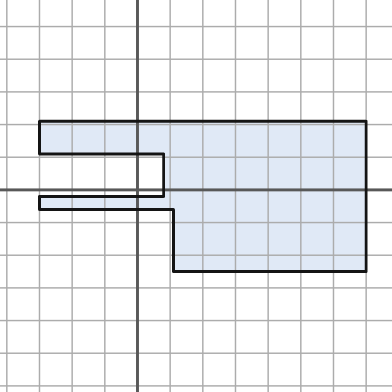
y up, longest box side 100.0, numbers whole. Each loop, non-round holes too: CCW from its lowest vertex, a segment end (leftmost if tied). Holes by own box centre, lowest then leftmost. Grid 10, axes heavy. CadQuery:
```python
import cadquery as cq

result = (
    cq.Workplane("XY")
    .moveTo(11.0, -25.0)
    .lineTo(70.0, -25.0)
    .lineTo(70.0, 21.0)
    .lineTo(-30.0, 21.0)
    .lineTo(-30.0, 11.0)
    .lineTo(8.0, 11.0)
    .lineTo(8.0, -2.0)
    .lineTo(-30.0, -2.0)
    .lineTo(-30.0, -6.0)
    .lineTo(11.0, -6.0)
    .close()
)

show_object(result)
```